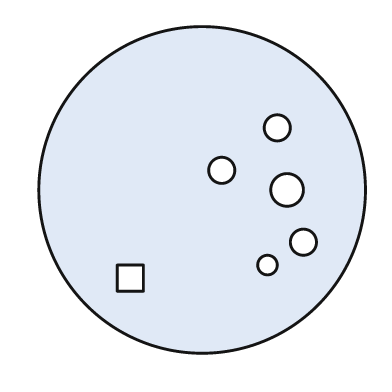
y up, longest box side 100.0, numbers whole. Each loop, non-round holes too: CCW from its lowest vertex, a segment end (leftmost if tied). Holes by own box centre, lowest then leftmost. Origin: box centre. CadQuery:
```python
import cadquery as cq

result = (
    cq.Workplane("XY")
    .moveTo(0.0, 0.0)
    .circle(50.0)
    .moveTo(-26.0, -31.0)
    .lineTo(-18.0, -31.0)
    .lineTo(-18.0, -23.0)
    .lineTo(-26.0, -23.0)
    .close()
    .moveTo(20.0, -23.0)
    .circle(3.0)
    .moveTo(31.0, -16.0)
    .circle(4.0)
    .moveTo(26.0, 0.0)
    .circle(5.0)
    .moveTo(6.0, 6.0)
    .circle(4.0)
    .moveTo(23.0, 19.0)
    .circle(4.0)
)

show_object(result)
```